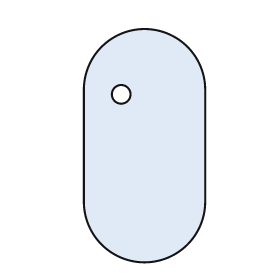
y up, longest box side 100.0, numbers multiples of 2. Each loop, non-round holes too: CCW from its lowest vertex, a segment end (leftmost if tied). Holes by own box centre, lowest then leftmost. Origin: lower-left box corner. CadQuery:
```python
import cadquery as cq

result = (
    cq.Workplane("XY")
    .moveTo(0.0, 26.0)
    .threePointArc((26.0, 0.0), (52.0, 26.0))
    .lineTo(52.0, 74.0)
    .threePointArc((26.0, 100.0), (0.0, 74.0))
    .close()
    .moveTo(16.0, 72.0)
    .circle(4.0)
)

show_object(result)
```